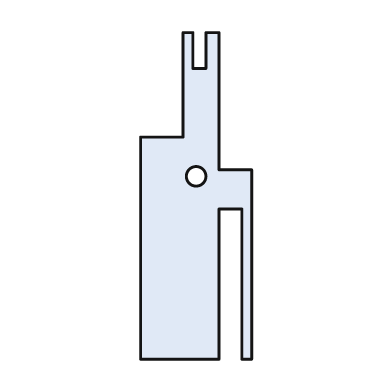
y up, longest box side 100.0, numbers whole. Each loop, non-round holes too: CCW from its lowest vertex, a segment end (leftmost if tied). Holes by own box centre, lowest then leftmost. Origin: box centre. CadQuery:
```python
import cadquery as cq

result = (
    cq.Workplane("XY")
    .moveTo(-17.0, -50.0)
    .lineTo(7.0, -50.0)
    .lineTo(7.0, -4.0)
    .lineTo(14.0, -4.0)
    .lineTo(14.0, -50.0)
    .lineTo(17.0, -50.0)
    .lineTo(17.0, 8.0)
    .lineTo(7.0, 8.0)
    .lineTo(7.0, 50.0)
    .lineTo(3.0, 50.0)
    .lineTo(3.0, 39.0)
    .lineTo(-1.0, 39.0)
    .lineTo(-1.0, 50.0)
    .lineTo(-4.0, 50.0)
    .lineTo(-4.0, 18.0)
    .lineTo(-17.0, 18.0)
    .close()
    .moveTo(0.0, 6.0)
    .circle(3.0)
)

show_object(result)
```